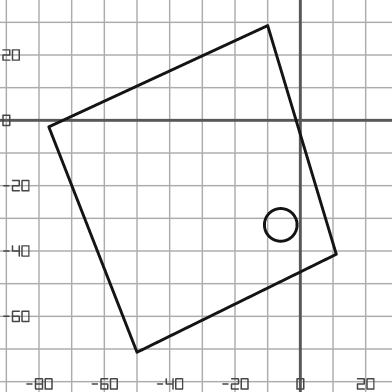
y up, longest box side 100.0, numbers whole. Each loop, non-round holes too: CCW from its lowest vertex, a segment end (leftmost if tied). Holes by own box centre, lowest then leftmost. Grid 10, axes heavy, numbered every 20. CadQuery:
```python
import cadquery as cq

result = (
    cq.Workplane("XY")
    .moveTo(-50.0, -71.0)
    .lineTo(11.0, -41.0)
    .lineTo(-10.0, 29.0)
    .lineTo(-77.0, -2.0)
    .close()
    .moveTo(-6.0, -32.0)
    .circle(5.0)
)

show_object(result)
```